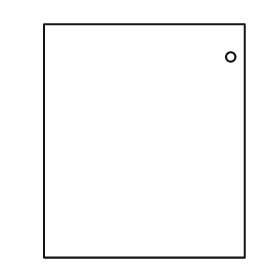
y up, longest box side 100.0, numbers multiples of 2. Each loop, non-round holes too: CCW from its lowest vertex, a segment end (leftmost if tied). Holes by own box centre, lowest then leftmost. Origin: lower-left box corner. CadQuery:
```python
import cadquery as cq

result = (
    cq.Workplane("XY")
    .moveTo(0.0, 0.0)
    .lineTo(86.0, 0.0)
    .lineTo(86.0, 100.0)
    .lineTo(0.0, 100.0)
    .close()
    .moveTo(80.0, 86.0)
    .circle(2.0)
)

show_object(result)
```